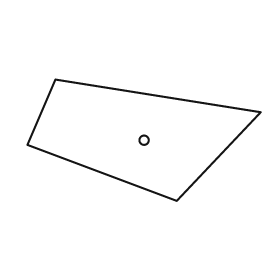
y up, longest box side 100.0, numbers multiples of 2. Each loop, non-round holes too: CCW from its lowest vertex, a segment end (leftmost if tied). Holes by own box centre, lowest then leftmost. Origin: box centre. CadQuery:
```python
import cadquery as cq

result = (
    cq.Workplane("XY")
    .moveTo(14.0, -26.0)
    .lineTo(50.0, 12.0)
    .lineTo(-38.0, 26.0)
    .lineTo(-50.0, -2.0)
    .close()
    .moveTo(0.0, 0.0)
    .circle(2.0)
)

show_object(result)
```